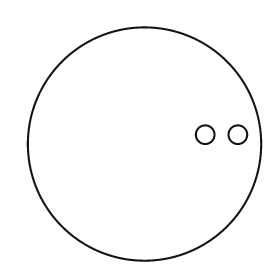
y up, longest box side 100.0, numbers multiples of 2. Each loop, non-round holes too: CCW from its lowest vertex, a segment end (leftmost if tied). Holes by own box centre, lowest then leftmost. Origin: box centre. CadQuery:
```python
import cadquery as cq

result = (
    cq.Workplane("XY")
    .moveTo(0.0, 0.0)
    .circle(50.0)
    .moveTo(26.0, 4.0)
    .circle(4.0)
    .moveTo(40.0, 4.0)
    .circle(4.0)
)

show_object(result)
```